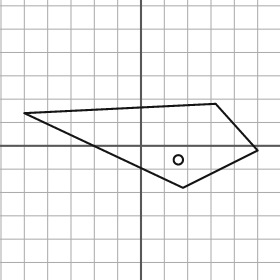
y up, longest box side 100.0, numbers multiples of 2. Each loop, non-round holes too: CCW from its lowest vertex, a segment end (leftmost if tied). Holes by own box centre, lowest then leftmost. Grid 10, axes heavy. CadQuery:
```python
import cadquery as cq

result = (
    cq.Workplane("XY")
    .moveTo(18.0, -18.0)
    .lineTo(50.0, -2.0)
    .lineTo(32.0, 18.0)
    .lineTo(-50.0, 14.0)
    .close()
    .moveTo(16.0, -6.0)
    .circle(2.0)
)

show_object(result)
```